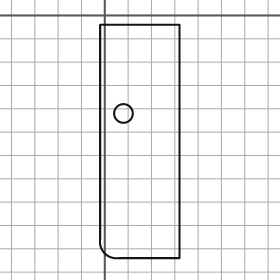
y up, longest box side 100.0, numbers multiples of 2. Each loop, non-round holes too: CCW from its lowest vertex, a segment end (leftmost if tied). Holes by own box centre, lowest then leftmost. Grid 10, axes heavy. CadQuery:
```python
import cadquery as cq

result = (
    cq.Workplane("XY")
    .moveTo(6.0, -104.0)
    .lineTo(32.0, -104.0)
    .lineTo(32.0, -4.0)
    .lineTo(-2.0, -4.0)
    .lineTo(-2.0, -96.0)
    .threePointArc((0.0, -102.0), (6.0, -104.0))
    .close()
    .moveTo(8.0, -42.0)
    .circle(4.0)
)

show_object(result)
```